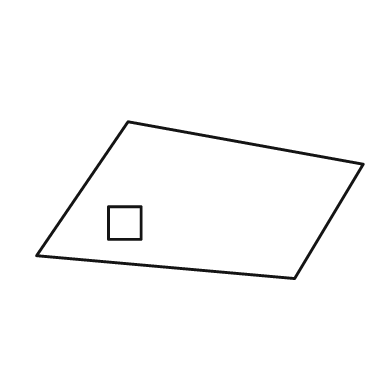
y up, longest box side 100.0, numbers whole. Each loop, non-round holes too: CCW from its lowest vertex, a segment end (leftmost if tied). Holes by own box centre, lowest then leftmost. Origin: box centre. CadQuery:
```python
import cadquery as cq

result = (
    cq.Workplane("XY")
    .moveTo(29.0, -24.0)
    .lineTo(50.0, 11.0)
    .lineTo(-22.0, 24.0)
    .lineTo(-50.0, -17.0)
    .close()
    .moveTo(-28.0, -12.0)
    .lineTo(-18.0, -12.0)
    .lineTo(-18.0, -2.0)
    .lineTo(-28.0, -2.0)
    .close()
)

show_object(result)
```